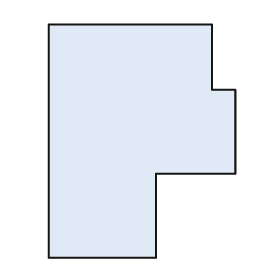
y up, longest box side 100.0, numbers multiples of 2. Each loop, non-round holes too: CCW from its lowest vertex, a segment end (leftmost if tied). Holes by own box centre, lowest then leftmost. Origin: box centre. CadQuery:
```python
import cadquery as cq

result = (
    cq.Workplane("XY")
    .moveTo(-40.0, -50.0)
    .lineTo(6.0, -50.0)
    .lineTo(6.0, -14.0)
    .lineTo(40.0, -14.0)
    .lineTo(40.0, 22.0)
    .lineTo(30.0, 22.0)
    .lineTo(30.0, 50.0)
    .lineTo(-40.0, 50.0)
    .close()
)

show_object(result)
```